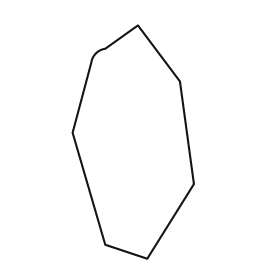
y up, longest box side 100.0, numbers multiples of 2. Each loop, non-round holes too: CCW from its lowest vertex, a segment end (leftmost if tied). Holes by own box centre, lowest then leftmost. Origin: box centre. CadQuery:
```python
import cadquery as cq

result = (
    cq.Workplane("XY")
    .moveTo(6.0, -50.0)
    .lineTo(26.0, -18.0)
    .lineTo(20.0, 26.0)
    .lineTo(2.0, 50.0)
    .lineTo(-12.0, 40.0)
    .threePointArc((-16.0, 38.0), (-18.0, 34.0))
    .lineTo(-26.0, 4.0)
    .lineTo(-12.0, -44.0)
    .close()
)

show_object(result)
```